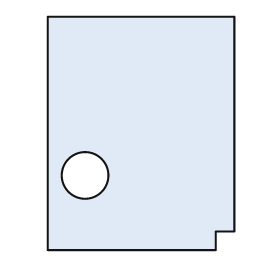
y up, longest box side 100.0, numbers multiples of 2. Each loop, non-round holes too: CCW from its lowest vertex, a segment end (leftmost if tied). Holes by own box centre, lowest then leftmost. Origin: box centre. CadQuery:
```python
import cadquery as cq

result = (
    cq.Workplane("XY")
    .moveTo(-40.0, -50.0)
    .lineTo(32.0, -50.0)
    .lineTo(32.0, -42.0)
    .lineTo(40.0, -42.0)
    .lineTo(40.0, 50.0)
    .lineTo(-40.0, 50.0)
    .close()
    .moveTo(-24.0, -18.0)
    .circle(10.0)
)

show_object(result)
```